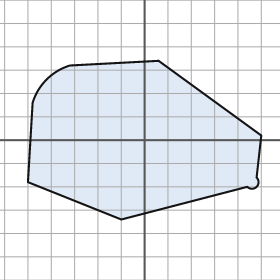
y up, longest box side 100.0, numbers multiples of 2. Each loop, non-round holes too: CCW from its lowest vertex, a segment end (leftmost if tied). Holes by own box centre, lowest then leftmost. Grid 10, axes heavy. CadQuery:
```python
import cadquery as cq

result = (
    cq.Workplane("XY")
    .moveTo(-10.0, -34.0)
    .lineTo(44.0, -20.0)
    .threePointArc((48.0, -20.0), (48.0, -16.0))
    .lineTo(50.0, 2.0)
    .lineTo(6.0, 34.0)
    .lineTo(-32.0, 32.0)
    .threePointArc((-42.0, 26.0), (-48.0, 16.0))
    .lineTo(-50.0, -18.0)
    .close()
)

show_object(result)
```